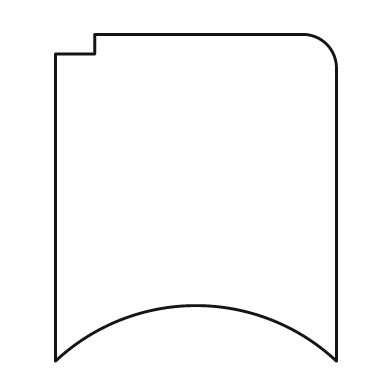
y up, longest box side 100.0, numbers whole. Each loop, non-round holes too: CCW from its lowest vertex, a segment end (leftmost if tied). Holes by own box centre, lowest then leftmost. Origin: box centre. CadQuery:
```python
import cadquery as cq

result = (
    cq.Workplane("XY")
    .moveTo(-43.0, -50.0)
    .threePointArc((0.0, -33.0), (43.0, -50.0))
    .lineTo(43.0, 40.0)
    .threePointArc((40.0, 47.0), (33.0, 50.0))
    .lineTo(-31.0, 50.0)
    .lineTo(-31.0, 44.0)
    .lineTo(-43.0, 44.0)
    .close()
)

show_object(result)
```